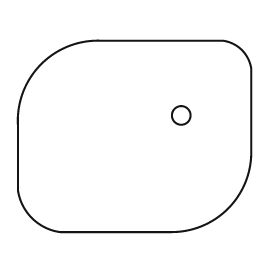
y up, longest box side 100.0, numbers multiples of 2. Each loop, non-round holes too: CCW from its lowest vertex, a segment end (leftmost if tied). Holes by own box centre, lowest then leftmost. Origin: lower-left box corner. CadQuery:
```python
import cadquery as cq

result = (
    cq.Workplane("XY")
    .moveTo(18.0, 0.0)
    .lineTo(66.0, 0.0)
    .threePointArc((90.0, 10.0), (100.0, 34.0))
    .lineTo(100.0, 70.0)
    .threePointArc((96.0, 78.0), (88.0, 82.0))
    .lineTo(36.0, 82.0)
    .threePointArc((10.0, 72.0), (0.0, 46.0))
    .lineTo(0.0, 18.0)
    .threePointArc((6.0, 6.0), (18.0, 0.0))
    .close()
    .moveTo(70.0, 50.0)
    .circle(4.0)
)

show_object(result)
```